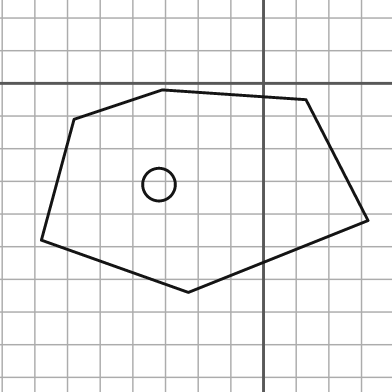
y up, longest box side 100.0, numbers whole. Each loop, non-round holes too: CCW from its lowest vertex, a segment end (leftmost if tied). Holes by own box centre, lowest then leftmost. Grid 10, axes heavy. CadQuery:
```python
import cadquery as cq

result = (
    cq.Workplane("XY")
    .moveTo(-23.0, -64.0)
    .lineTo(32.0, -42.0)
    .lineTo(13.0, -5.0)
    .lineTo(-31.0, -2.0)
    .lineTo(-58.0, -11.0)
    .lineTo(-68.0, -48.0)
    .close()
    .moveTo(-32.0, -31.0)
    .circle(5.0)
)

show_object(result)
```